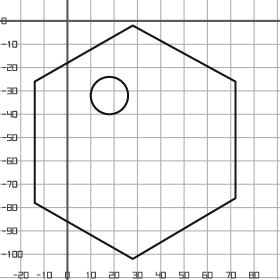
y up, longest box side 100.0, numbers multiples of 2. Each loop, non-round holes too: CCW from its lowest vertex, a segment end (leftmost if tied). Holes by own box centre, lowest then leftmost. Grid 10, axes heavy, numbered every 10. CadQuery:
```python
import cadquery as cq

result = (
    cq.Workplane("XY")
    .moveTo(28.0, -102.0)
    .lineTo(72.0, -76.0)
    .lineTo(72.0, -26.0)
    .lineTo(28.0, -2.0)
    .lineTo(-14.0, -26.0)
    .lineTo(-14.0, -78.0)
    .close()
    .moveTo(18.0, -32.0)
    .circle(8.0)
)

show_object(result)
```